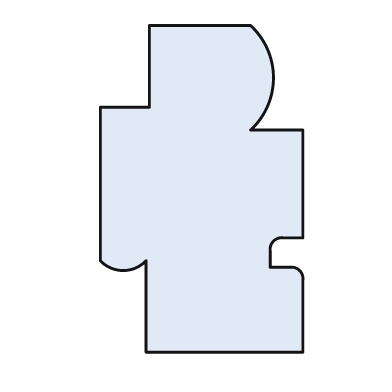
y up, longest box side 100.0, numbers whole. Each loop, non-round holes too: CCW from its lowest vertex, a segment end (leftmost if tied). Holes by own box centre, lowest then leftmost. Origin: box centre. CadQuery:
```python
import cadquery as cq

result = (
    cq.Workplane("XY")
    .moveTo(-17.0, -50.0)
    .lineTo(31.0, -50.0)
    .lineTo(31.0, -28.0)
    .threePointArc((30.0, -25.0), (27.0, -24.0))
    .lineTo(21.0, -24.0)
    .lineTo(21.0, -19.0)
    .threePointArc((22.0, -16.0), (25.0, -15.0))
    .lineTo(31.0, -15.0)
    .lineTo(31.0, 18.0)
    .lineTo(15.0, 18.0)
    .threePointArc((22.0, 34.0), (15.0, 50.0))
    .lineTo(-16.0, 50.0)
    .lineTo(-16.0, 25.0)
    .lineTo(-31.0, 25.0)
    .lineTo(-31.0, -22.0)
    .threePointArc((-24.0, -25.0), (-17.0, -22.0))
    .close()
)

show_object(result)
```